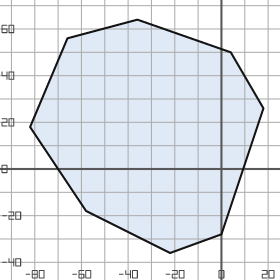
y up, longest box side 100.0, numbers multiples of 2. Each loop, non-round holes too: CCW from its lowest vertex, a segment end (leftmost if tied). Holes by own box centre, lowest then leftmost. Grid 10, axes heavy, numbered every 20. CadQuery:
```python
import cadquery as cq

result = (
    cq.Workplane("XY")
    .moveTo(-22.0, -36.0)
    .lineTo(0.0, -28.0)
    .lineTo(18.0, 26.0)
    .lineTo(4.0, 50.0)
    .lineTo(-36.0, 64.0)
    .lineTo(-66.0, 56.0)
    .lineTo(-82.0, 18.0)
    .lineTo(-58.0, -18.0)
    .close()
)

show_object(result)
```